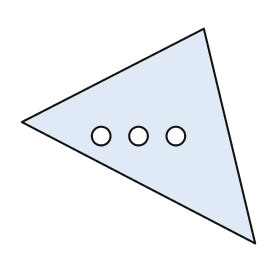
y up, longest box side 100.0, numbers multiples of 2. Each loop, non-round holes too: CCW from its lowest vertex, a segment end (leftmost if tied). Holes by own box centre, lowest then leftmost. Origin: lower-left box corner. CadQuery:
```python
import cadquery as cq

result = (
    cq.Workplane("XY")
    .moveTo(100.0, 0.0)
    .lineTo(78.0, 92.0)
    .lineTo(0.0, 52.0)
    .close()
    .moveTo(34.0, 46.0)
    .circle(4.0)
    .moveTo(50.0, 46.0)
    .circle(4.0)
    .moveTo(66.0, 46.0)
    .circle(4.0)
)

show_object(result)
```